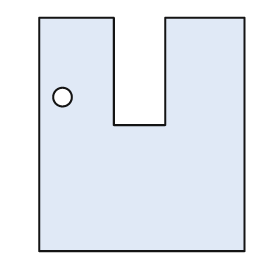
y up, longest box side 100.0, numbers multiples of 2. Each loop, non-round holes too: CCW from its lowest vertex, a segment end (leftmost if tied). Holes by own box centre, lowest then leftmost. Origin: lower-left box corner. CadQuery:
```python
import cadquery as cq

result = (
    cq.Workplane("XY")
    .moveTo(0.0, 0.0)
    .lineTo(88.0, 0.0)
    .lineTo(88.0, 100.0)
    .lineTo(54.0, 100.0)
    .lineTo(54.0, 54.0)
    .lineTo(32.0, 54.0)
    .lineTo(32.0, 100.0)
    .lineTo(0.0, 100.0)
    .close()
    .moveTo(10.0, 66.0)
    .circle(4.0)
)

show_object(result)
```